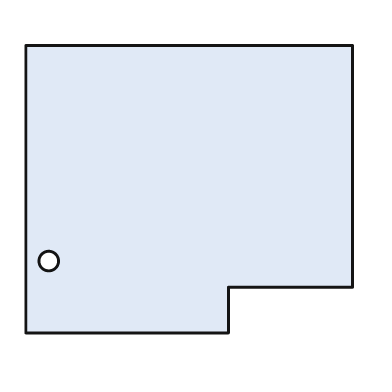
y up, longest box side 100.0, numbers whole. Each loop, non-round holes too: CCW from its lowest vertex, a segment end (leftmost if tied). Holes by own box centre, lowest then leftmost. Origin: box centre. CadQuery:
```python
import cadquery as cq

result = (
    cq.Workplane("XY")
    .moveTo(-50.0, -44.0)
    .lineTo(12.0, -44.0)
    .lineTo(12.0, -30.0)
    .lineTo(50.0, -30.0)
    .lineTo(50.0, 44.0)
    .lineTo(-50.0, 44.0)
    .close()
    .moveTo(-43.0, -22.0)
    .circle(3.0)
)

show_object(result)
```